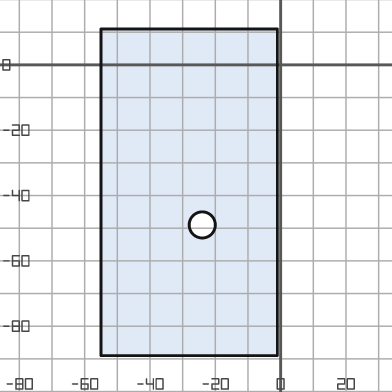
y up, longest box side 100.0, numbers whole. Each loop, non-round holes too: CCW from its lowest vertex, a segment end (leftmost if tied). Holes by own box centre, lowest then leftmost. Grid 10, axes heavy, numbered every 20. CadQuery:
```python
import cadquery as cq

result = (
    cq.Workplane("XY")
    .moveTo(-55.0, -89.0)
    .lineTo(-1.0, -89.0)
    .lineTo(-1.0, 11.0)
    .lineTo(-55.0, 11.0)
    .close()
    .moveTo(-24.0, -49.0)
    .circle(4.0)
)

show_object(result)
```